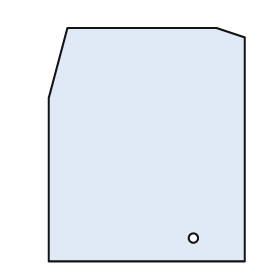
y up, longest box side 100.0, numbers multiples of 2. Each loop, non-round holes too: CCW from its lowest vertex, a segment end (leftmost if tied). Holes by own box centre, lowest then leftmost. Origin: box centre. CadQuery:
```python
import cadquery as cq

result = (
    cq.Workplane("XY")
    .moveTo(-42.0, -50.0)
    .lineTo(42.0, -50.0)
    .lineTo(42.0, 46.0)
    .lineTo(30.0, 50.0)
    .lineTo(-34.0, 50.0)
    .lineTo(-42.0, 20.0)
    .close()
    .moveTo(20.0, -40.0)
    .circle(2.0)
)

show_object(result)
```